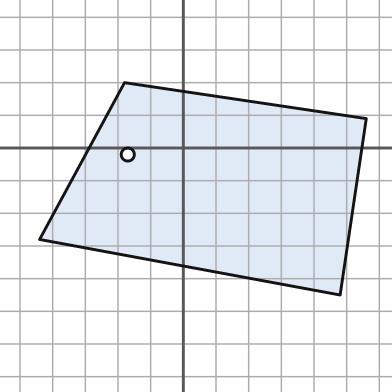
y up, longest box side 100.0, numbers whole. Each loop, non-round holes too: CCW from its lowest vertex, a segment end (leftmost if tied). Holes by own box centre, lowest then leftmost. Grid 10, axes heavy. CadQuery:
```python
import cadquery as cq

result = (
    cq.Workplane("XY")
    .moveTo(48.0, -45.0)
    .lineTo(56.0, 9.0)
    .lineTo(-18.0, 20.0)
    .lineTo(-44.0, -28.0)
    .close()
    .moveTo(-17.0, -2.0)
    .circle(2.0)
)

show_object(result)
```